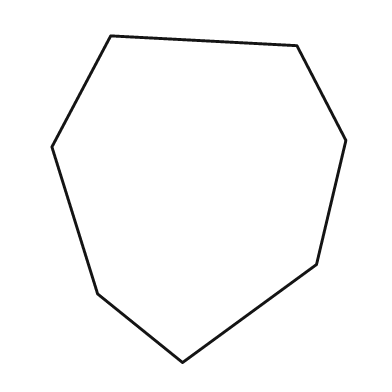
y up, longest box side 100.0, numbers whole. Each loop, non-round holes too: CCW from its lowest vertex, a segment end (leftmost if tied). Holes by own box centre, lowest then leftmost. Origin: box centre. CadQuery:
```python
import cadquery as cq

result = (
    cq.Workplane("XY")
    .moveTo(-5.0, -50.0)
    .lineTo(36.0, -20.0)
    .lineTo(45.0, 18.0)
    .lineTo(30.0, 47.0)
    .lineTo(-27.0, 50.0)
    .lineTo(-45.0, 16.0)
    .lineTo(-31.0, -29.0)
    .close()
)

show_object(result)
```